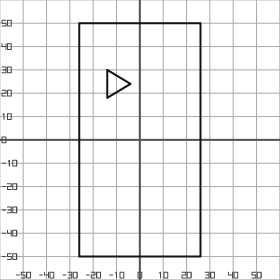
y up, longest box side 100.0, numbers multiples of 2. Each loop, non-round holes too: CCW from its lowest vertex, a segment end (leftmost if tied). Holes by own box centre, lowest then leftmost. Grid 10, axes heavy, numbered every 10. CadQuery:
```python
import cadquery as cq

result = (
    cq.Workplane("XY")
    .moveTo(-26.0, -50.0)
    .lineTo(26.0, -50.0)
    .lineTo(26.0, 50.0)
    .lineTo(-26.0, 50.0)
    .close()
    .moveTo(-14.0, 18.0)
    .lineTo(-4.0, 24.0)
    .lineTo(-14.0, 30.0)
    .close()
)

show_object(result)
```